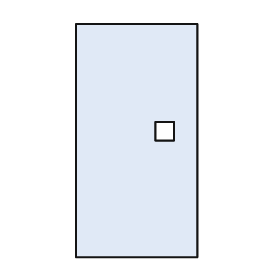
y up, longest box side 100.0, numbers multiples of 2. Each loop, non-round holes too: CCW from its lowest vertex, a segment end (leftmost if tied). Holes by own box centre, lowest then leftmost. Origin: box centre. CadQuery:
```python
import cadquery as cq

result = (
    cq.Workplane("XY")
    .moveTo(-26.0, -50.0)
    .lineTo(26.0, -50.0)
    .lineTo(26.0, 50.0)
    .lineTo(-26.0, 50.0)
    .close()
    .moveTo(8.0, 0.0)
    .lineTo(16.0, 0.0)
    .lineTo(16.0, 8.0)
    .lineTo(8.0, 8.0)
    .close()
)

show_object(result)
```